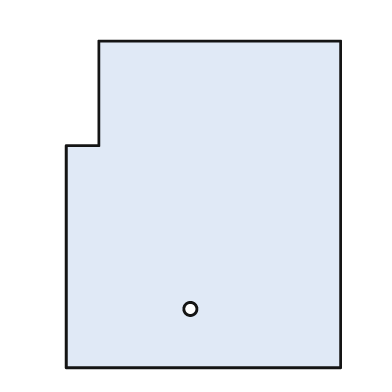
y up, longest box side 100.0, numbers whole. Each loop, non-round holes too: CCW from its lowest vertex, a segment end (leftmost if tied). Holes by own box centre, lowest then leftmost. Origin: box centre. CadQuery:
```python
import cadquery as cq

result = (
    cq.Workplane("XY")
    .moveTo(-42.0, -50.0)
    .lineTo(42.0, -50.0)
    .lineTo(42.0, 50.0)
    .lineTo(-32.0, 50.0)
    .lineTo(-32.0, 18.0)
    .lineTo(-42.0, 18.0)
    .close()
    .moveTo(-4.0, -32.0)
    .circle(2.0)
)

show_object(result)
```